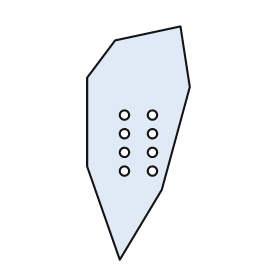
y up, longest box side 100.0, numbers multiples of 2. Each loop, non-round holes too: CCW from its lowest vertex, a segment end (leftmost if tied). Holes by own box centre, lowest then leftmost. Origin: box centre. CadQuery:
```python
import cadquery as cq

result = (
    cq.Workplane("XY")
    .moveTo(-8.0, -50.0)
    .lineTo(10.0, -20.0)
    .lineTo(22.0, 24.0)
    .lineTo(18.0, 50.0)
    .lineTo(-10.0, 44.0)
    .lineTo(-22.0, 28.0)
    .lineTo(-22.0, -10.0)
    .close()
    .moveTo(-6.0, -12.0)
    .circle(2.0)
    .moveTo(6.0, -12.0)
    .circle(2.0)
    .moveTo(-6.0, -4.0)
    .circle(2.0)
    .moveTo(6.0, -4.0)
    .circle(2.0)
    .moveTo(-6.0, 4.0)
    .circle(2.0)
    .moveTo(6.0, 4.0)
    .circle(2.0)
    .moveTo(-6.0, 12.0)
    .circle(2.0)
    .moveTo(6.0, 12.0)
    .circle(2.0)
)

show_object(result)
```